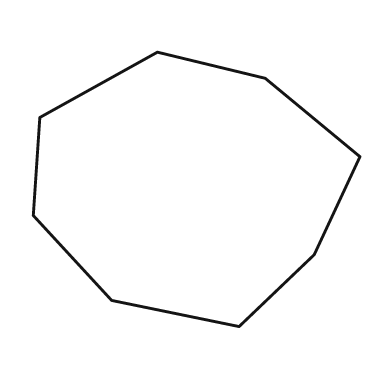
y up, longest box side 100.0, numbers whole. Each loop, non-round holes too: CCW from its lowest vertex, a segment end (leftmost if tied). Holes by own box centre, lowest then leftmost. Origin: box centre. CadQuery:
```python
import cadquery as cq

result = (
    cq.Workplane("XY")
    .moveTo(13.0, -42.0)
    .lineTo(36.0, -20.0)
    .lineTo(50.0, 10.0)
    .lineTo(21.0, 34.0)
    .lineTo(-12.0, 42.0)
    .lineTo(-48.0, 22.0)
    .lineTo(-50.0, -8.0)
    .lineTo(-26.0, -34.0)
    .close()
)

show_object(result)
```